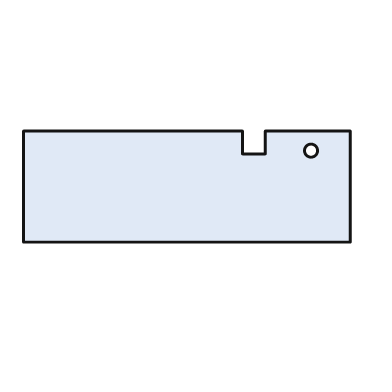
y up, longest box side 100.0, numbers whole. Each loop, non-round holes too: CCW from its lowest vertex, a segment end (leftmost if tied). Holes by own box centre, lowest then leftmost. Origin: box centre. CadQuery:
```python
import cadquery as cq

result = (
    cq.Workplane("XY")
    .moveTo(-50.0, -17.0)
    .lineTo(50.0, -17.0)
    .lineTo(50.0, 17.0)
    .lineTo(24.0, 17.0)
    .lineTo(24.0, 10.0)
    .lineTo(17.0, 10.0)
    .lineTo(17.0, 17.0)
    .lineTo(-50.0, 17.0)
    .close()
    .moveTo(38.0, 11.0)
    .circle(2.0)
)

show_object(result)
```